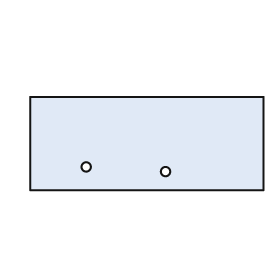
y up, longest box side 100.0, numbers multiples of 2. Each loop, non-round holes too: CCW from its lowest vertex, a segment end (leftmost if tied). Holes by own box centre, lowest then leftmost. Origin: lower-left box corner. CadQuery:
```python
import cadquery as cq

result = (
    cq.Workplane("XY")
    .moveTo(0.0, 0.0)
    .lineTo(100.0, 0.0)
    .lineTo(100.0, 40.0)
    .lineTo(0.0, 40.0)
    .close()
    .moveTo(58.0, 8.0)
    .circle(2.0)
    .moveTo(24.0, 10.0)
    .circle(2.0)
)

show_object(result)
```